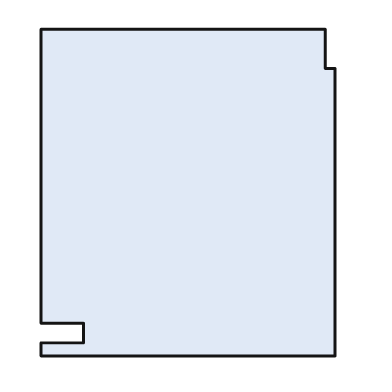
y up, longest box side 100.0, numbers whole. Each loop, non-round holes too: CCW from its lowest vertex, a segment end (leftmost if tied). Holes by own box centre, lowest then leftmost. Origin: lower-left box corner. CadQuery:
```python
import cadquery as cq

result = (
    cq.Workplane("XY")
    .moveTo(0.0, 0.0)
    .lineTo(90.0, 0.0)
    .lineTo(90.0, 88.0)
    .lineTo(87.0, 88.0)
    .lineTo(87.0, 100.0)
    .lineTo(0.0, 100.0)
    .lineTo(0.0, 10.0)
    .lineTo(13.0, 10.0)
    .lineTo(13.0, 4.0)
    .lineTo(0.0, 4.0)
    .close()
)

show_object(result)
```